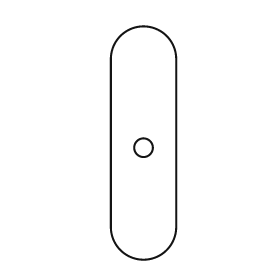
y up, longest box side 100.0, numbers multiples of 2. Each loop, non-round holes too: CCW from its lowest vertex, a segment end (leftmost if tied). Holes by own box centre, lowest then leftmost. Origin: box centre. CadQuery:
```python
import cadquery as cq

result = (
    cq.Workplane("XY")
    .moveTo(-14.0, -36.0)
    .threePointArc((0.0, -50.0), (14.0, -36.0))
    .lineTo(14.0, 36.0)
    .threePointArc((0.0, 50.0), (-14.0, 36.0))
    .close()
    .moveTo(0.0, -2.0)
    .circle(4.0)
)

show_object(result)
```